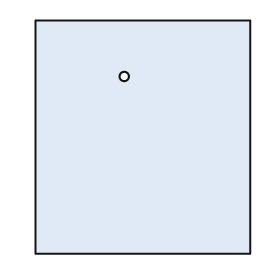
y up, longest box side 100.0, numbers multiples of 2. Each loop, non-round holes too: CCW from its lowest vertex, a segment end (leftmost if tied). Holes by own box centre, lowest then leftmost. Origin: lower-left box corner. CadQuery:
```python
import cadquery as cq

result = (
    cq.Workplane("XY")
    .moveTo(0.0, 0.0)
    .lineTo(92.0, 0.0)
    .lineTo(92.0, 100.0)
    .lineTo(0.0, 100.0)
    .close()
    .moveTo(38.0, 76.0)
    .circle(2.0)
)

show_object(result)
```